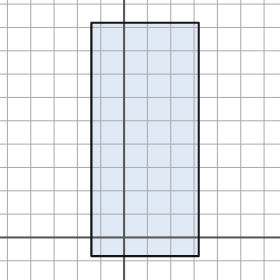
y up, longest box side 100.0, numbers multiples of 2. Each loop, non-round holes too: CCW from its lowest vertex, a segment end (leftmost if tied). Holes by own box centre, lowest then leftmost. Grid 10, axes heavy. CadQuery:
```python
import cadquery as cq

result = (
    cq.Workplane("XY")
    .moveTo(-14.0, -8.0)
    .lineTo(32.0, -8.0)
    .lineTo(32.0, 92.0)
    .lineTo(-14.0, 92.0)
    .close()
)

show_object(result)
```